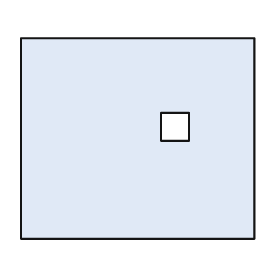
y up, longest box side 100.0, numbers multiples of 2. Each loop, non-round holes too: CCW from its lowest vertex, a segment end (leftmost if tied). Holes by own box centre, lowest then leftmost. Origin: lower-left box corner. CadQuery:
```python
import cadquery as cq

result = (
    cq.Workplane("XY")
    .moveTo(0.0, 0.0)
    .lineTo(100.0, 0.0)
    .lineTo(100.0, 86.0)
    .lineTo(0.0, 86.0)
    .close()
    .moveTo(60.0, 42.0)
    .lineTo(72.0, 42.0)
    .lineTo(72.0, 54.0)
    .lineTo(60.0, 54.0)
    .close()
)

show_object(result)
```